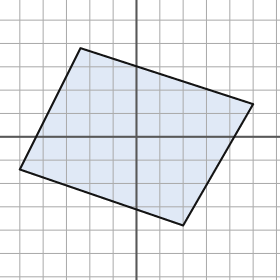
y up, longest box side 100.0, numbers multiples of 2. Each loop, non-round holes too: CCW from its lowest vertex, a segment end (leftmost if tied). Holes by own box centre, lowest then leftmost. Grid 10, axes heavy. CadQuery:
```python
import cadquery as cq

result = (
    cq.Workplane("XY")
    .moveTo(20.0, -38.0)
    .lineTo(50.0, 14.0)
    .lineTo(-24.0, 38.0)
    .lineTo(-50.0, -14.0)
    .close()
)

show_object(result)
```